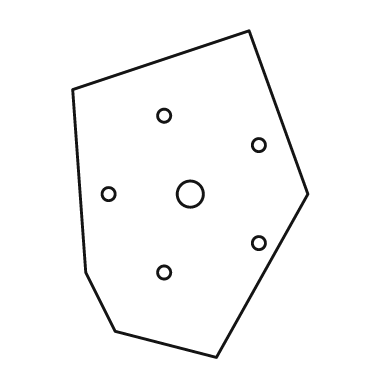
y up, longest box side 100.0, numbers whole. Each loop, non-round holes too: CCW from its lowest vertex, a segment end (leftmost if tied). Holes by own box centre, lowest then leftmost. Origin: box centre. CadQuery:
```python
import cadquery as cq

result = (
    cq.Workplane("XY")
    .moveTo(8.0, -50.0)
    .lineTo(36.0, 0.0)
    .lineTo(18.0, 50.0)
    .lineTo(-36.0, 32.0)
    .lineTo(-32.0, -24.0)
    .lineTo(-23.0, -42.0)
    .close()
    .moveTo(-8.0, -24.0)
    .circle(2.0)
    .moveTo(21.0, -15.0)
    .circle(2.0)
    .moveTo(-25.0, 0.0)
    .circle(2.0)
    .moveTo(0.0, 0.0)
    .circle(4.0)
    .moveTo(21.0, 15.0)
    .circle(2.0)
    .moveTo(-8.0, 24.0)
    .circle(2.0)
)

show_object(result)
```